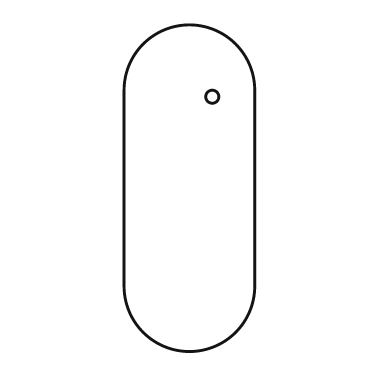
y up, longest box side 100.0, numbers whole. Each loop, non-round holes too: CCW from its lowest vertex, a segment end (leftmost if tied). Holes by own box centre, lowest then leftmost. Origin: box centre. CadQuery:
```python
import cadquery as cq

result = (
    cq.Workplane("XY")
    .moveTo(-20.0, -30.0)
    .threePointArc((0.0, -50.0), (20.0, -30.0))
    .lineTo(20.0, 30.0)
    .threePointArc((0.0, 50.0), (-20.0, 30.0))
    .close()
    .moveTo(7.0, 28.0)
    .circle(2.0)
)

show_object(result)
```